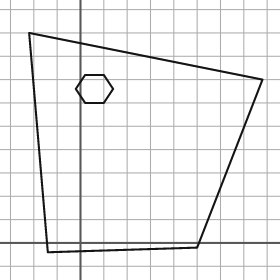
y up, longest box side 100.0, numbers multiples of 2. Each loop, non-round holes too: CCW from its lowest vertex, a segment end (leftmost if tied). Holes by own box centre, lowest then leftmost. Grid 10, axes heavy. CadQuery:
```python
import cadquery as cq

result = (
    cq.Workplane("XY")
    .moveTo(-14.0, -4.0)
    .lineTo(50.0, -2.0)
    .lineTo(78.0, 70.0)
    .lineTo(-22.0, 90.0)
    .close()
    .moveTo(2.0, 60.0)
    .lineTo(10.0, 60.0)
    .lineTo(14.0, 66.0)
    .lineTo(10.0, 72.0)
    .lineTo(2.0, 72.0)
    .lineTo(-2.0, 66.0)
    .close()
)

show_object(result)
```